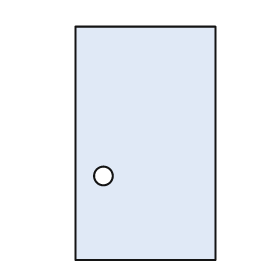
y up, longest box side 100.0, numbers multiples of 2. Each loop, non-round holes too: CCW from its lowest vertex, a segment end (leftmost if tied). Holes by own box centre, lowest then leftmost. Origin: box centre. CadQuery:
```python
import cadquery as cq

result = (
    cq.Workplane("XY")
    .moveTo(-30.0, -50.0)
    .lineTo(30.0, -50.0)
    .lineTo(30.0, 50.0)
    .lineTo(-30.0, 50.0)
    .close()
    .moveTo(-18.0, -14.0)
    .circle(4.0)
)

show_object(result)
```